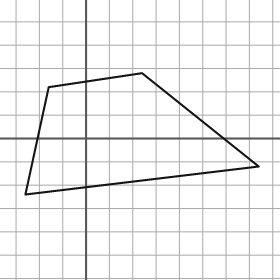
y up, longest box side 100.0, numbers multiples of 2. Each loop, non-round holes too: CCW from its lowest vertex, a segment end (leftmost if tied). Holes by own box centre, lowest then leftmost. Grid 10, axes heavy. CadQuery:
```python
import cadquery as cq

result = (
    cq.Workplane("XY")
    .moveTo(-26.0, -24.0)
    .lineTo(74.0, -12.0)
    .lineTo(24.0, 28.0)
    .lineTo(-16.0, 22.0)
    .close()
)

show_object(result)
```